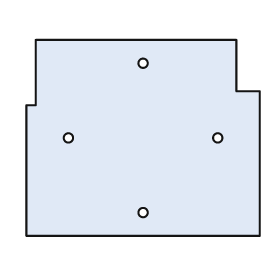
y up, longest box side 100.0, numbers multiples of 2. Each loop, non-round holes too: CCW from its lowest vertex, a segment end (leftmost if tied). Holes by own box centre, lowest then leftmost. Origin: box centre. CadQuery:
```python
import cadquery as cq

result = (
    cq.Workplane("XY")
    .moveTo(-50.0, -42.0)
    .lineTo(50.0, -42.0)
    .lineTo(50.0, 20.0)
    .lineTo(40.0, 20.0)
    .lineTo(40.0, 42.0)
    .lineTo(-46.0, 42.0)
    .lineTo(-46.0, 14.0)
    .lineTo(-50.0, 14.0)
    .close()
    .moveTo(0.0, -32.0)
    .circle(2.0)
    .moveTo(-32.0, 0.0)
    .circle(2.0)
    .moveTo(32.0, 0.0)
    .circle(2.0)
    .moveTo(0.0, 32.0)
    .circle(2.0)
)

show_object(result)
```